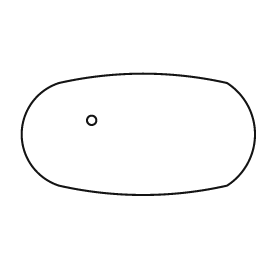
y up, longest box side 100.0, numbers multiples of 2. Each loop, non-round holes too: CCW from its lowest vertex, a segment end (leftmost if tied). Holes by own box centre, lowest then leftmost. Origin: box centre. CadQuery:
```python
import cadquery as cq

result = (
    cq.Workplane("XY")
    .moveTo(-34.0, -22.0)
    .threePointArc((2.0, -26.0), (38.0, -22.0))
    .threePointArc((50.0, 0.0), (38.0, 22.0))
    .threePointArc((2.0, 26.0), (-34.0, 22.0))
    .threePointArc((-50.0, 0.0), (-34.0, -22.0))
    .close()
    .moveTo(-20.0, 6.0)
    .circle(2.0)
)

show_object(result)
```